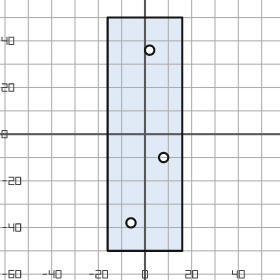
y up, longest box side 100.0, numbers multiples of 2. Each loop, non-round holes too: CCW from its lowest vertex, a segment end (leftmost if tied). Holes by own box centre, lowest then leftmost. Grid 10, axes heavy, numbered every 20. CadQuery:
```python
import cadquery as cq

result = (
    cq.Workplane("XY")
    .moveTo(-16.0, -50.0)
    .lineTo(16.0, -50.0)
    .lineTo(16.0, 50.0)
    .lineTo(-16.0, 50.0)
    .close()
    .moveTo(-6.0, -38.0)
    .circle(2.0)
    .moveTo(8.0, -10.0)
    .circle(2.0)
    .moveTo(2.0, 36.0)
    .circle(2.0)
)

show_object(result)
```